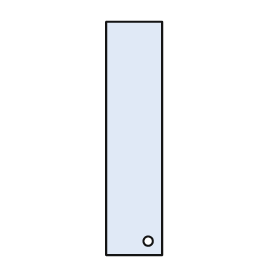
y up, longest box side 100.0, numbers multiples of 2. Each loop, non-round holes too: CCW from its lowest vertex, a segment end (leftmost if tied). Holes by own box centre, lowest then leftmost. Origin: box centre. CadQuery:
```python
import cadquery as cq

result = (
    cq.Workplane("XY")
    .moveTo(-12.0, -50.0)
    .lineTo(12.0, -50.0)
    .lineTo(12.0, 50.0)
    .lineTo(-12.0, 50.0)
    .close()
    .moveTo(6.0, -44.0)
    .circle(2.0)
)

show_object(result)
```